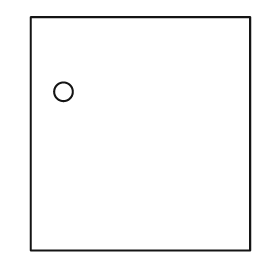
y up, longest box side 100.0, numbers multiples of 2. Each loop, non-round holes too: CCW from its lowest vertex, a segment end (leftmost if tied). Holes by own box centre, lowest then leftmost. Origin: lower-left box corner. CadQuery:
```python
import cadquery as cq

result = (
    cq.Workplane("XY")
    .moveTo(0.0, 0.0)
    .lineTo(94.0, 0.0)
    .lineTo(94.0, 100.0)
    .lineTo(0.0, 100.0)
    .close()
    .moveTo(14.0, 68.0)
    .circle(4.0)
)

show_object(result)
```